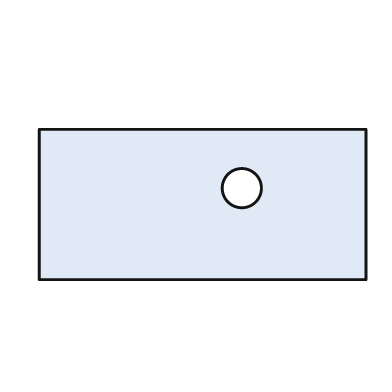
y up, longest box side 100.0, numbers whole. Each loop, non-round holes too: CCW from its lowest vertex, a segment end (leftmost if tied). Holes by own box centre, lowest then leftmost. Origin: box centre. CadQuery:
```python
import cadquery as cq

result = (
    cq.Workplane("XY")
    .moveTo(-50.0, -23.0)
    .lineTo(50.0, -23.0)
    .lineTo(50.0, 23.0)
    .lineTo(-50.0, 23.0)
    .close()
    .moveTo(12.0, 5.0)
    .circle(6.0)
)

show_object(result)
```